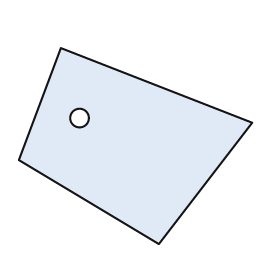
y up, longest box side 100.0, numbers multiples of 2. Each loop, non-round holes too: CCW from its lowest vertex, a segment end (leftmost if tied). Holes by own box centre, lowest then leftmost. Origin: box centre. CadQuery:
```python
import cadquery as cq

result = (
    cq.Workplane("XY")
    .moveTo(10.0, -42.0)
    .lineTo(50.0, 10.0)
    .lineTo(-32.0, 42.0)
    .lineTo(-50.0, -6.0)
    .close()
    .moveTo(-24.0, 12.0)
    .circle(4.0)
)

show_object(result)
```